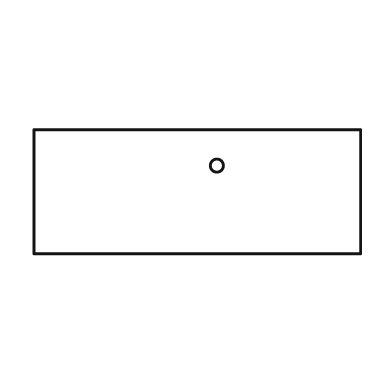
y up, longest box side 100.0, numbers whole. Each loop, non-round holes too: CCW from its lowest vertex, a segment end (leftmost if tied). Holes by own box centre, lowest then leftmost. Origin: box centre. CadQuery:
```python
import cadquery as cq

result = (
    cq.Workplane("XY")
    .moveTo(-50.0, -19.0)
    .lineTo(50.0, -19.0)
    .lineTo(50.0, 19.0)
    .lineTo(-50.0, 19.0)
    .close()
    .moveTo(6.0, 8.0)
    .circle(2.0)
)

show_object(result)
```